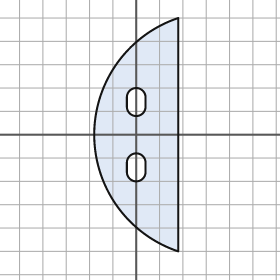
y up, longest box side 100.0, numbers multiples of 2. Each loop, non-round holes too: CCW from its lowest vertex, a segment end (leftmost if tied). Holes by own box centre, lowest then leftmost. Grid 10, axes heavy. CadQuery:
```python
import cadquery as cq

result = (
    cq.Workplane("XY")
    .moveTo(18.0, -50.0)
    .lineTo(18.0, 50.0)
    .threePointArc((-18.0, 0.0), (18.0, -50.0))
    .close()
    .moveTo(-4.0, -16.0)
    .threePointArc((0.0, -20.0), (4.0, -16.0))
    .lineTo(4.0, -12.0)
    .threePointArc((0.0, -8.0), (-4.0, -12.0))
    .close()
    .moveTo(-4.0, 12.0)
    .threePointArc((0.0, 8.0), (4.0, 12.0))
    .lineTo(4.0, 16.0)
    .threePointArc((0.0, 20.0), (-4.0, 16.0))
    .close()
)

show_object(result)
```